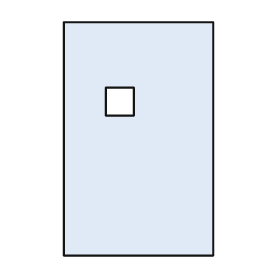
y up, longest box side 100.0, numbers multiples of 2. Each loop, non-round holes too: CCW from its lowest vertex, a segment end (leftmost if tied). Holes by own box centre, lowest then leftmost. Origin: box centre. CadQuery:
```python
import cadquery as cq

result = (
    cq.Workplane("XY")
    .moveTo(-32.0, -50.0)
    .lineTo(32.0, -50.0)
    .lineTo(32.0, 50.0)
    .lineTo(-32.0, 50.0)
    .close()
    .moveTo(-14.0, 10.0)
    .lineTo(-2.0, 10.0)
    .lineTo(-2.0, 22.0)
    .lineTo(-14.0, 22.0)
    .close()
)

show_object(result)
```